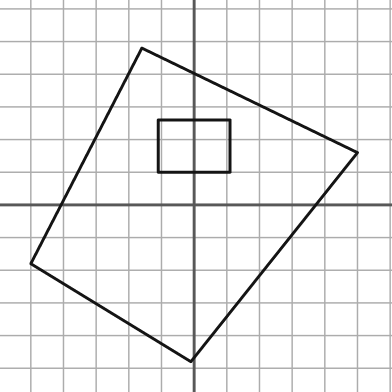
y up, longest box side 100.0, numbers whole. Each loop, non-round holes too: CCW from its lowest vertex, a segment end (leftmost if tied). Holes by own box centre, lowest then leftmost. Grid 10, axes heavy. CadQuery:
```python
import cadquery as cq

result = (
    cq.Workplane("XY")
    .moveTo(-1.0, -48.0)
    .lineTo(50.0, 16.0)
    .lineTo(-16.0, 48.0)
    .lineTo(-50.0, -18.0)
    .close()
    .moveTo(-11.0, 10.0)
    .lineTo(11.0, 10.0)
    .lineTo(11.0, 26.0)
    .lineTo(-11.0, 26.0)
    .close()
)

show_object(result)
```